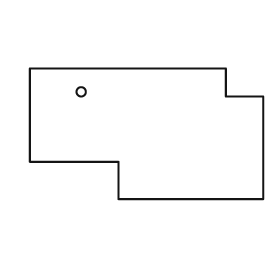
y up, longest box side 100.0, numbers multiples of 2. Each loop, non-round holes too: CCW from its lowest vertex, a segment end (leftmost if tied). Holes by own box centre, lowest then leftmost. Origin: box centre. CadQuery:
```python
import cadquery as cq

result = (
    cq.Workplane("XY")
    .moveTo(-12.0, -28.0)
    .lineTo(50.0, -28.0)
    .lineTo(50.0, 16.0)
    .lineTo(34.0, 16.0)
    .lineTo(34.0, 28.0)
    .lineTo(-50.0, 28.0)
    .lineTo(-50.0, -12.0)
    .lineTo(-12.0, -12.0)
    .close()
    .moveTo(-28.0, 18.0)
    .circle(2.0)
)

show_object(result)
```